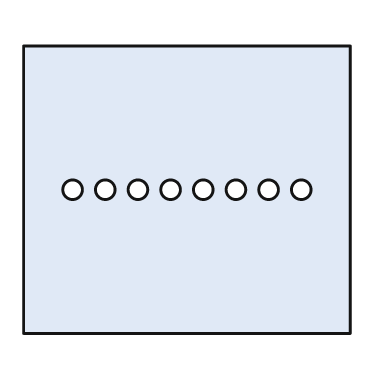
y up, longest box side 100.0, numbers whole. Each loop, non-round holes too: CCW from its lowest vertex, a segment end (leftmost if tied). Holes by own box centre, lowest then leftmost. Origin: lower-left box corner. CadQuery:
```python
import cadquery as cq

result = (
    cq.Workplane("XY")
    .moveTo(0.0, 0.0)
    .lineTo(100.0, 0.0)
    .lineTo(100.0, 88.0)
    .lineTo(0.0, 88.0)
    .close()
    .moveTo(15.0, 44.0)
    .circle(3.0)
    .moveTo(25.0, 44.0)
    .circle(3.0)
    .moveTo(35.0, 44.0)
    .circle(3.0)
    .moveTo(45.0, 44.0)
    .circle(3.0)
    .moveTo(55.0, 44.0)
    .circle(3.0)
    .moveTo(65.0, 44.0)
    .circle(3.0)
    .moveTo(75.0, 44.0)
    .circle(3.0)
    .moveTo(85.0, 44.0)
    .circle(3.0)
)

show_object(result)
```